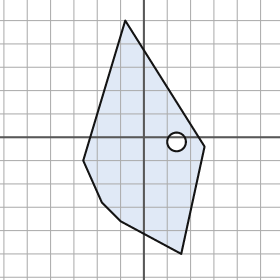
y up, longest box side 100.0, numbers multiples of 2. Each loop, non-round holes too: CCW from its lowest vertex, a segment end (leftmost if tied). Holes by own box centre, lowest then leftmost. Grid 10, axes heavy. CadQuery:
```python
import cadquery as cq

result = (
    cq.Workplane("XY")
    .moveTo(16.0, -50.0)
    .lineTo(26.0, -4.0)
    .lineTo(-8.0, 50.0)
    .lineTo(-26.0, -10.0)
    .lineTo(-18.0, -28.0)
    .lineTo(-10.0, -36.0)
    .close()
    .moveTo(14.0, -2.0)
    .circle(4.0)
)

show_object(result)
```